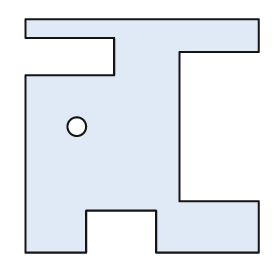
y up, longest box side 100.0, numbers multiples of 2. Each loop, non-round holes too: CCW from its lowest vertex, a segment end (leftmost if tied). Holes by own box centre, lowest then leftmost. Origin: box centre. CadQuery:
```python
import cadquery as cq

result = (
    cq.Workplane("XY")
    .moveTo(-50.0, -50.0)
    .lineTo(-24.0, -50.0)
    .lineTo(-24.0, -32.0)
    .lineTo(6.0, -32.0)
    .lineTo(6.0, -50.0)
    .lineTo(50.0, -50.0)
    .lineTo(50.0, -28.0)
    .lineTo(16.0, -28.0)
    .lineTo(16.0, 36.0)
    .lineTo(50.0, 36.0)
    .lineTo(50.0, 50.0)
    .lineTo(-50.0, 50.0)
    .lineTo(-50.0, 42.0)
    .lineTo(-12.0, 42.0)
    .lineTo(-12.0, 26.0)
    .lineTo(-50.0, 26.0)
    .close()
    .moveTo(-28.0, 4.0)
    .circle(4.0)
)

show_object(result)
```